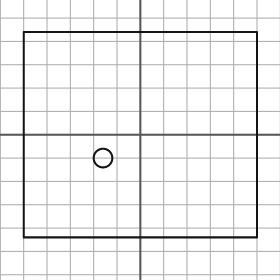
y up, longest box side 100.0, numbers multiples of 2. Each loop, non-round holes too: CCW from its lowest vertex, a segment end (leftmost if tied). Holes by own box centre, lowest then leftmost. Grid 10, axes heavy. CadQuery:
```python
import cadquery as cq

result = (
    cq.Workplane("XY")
    .moveTo(-50.0, -44.0)
    .lineTo(50.0, -44.0)
    .lineTo(50.0, 44.0)
    .lineTo(-50.0, 44.0)
    .close()
    .moveTo(-16.0, -10.0)
    .circle(4.0)
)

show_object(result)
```